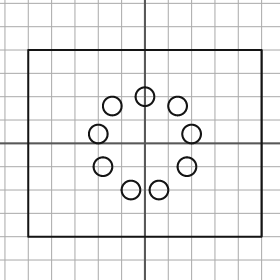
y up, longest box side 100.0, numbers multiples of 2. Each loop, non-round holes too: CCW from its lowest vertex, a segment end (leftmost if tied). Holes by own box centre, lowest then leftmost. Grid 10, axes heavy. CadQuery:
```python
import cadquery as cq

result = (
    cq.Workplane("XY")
    .moveTo(-50.0, -40.0)
    .lineTo(50.0, -40.0)
    .lineTo(50.0, 40.0)
    .lineTo(-50.0, 40.0)
    .close()
    .moveTo(-6.0, -20.0)
    .circle(4.0)
    .moveTo(6.0, -20.0)
    .circle(4.0)
    .moveTo(-18.0, -10.0)
    .circle(4.0)
    .moveTo(18.0, -10.0)
    .circle(4.0)
    .moveTo(-20.0, 4.0)
    .circle(4.0)
    .moveTo(20.0, 4.0)
    .circle(4.0)
    .moveTo(-14.0, 16.0)
    .circle(4.0)
    .moveTo(14.0, 16.0)
    .circle(4.0)
    .moveTo(0.0, 20.0)
    .circle(4.0)
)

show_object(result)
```